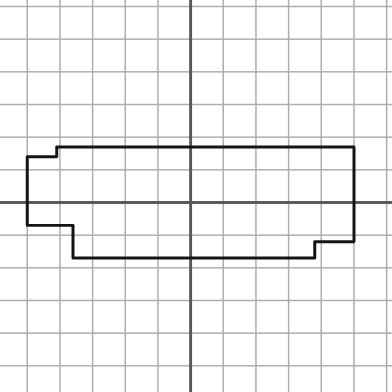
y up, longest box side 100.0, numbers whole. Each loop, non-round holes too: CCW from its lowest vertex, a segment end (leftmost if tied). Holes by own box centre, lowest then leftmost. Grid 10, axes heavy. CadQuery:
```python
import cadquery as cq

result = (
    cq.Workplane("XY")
    .moveTo(-36.0, -17.0)
    .lineTo(38.0, -17.0)
    .lineTo(38.0, -12.0)
    .lineTo(50.0, -12.0)
    .lineTo(50.0, 17.0)
    .lineTo(-41.0, 17.0)
    .lineTo(-41.0, 14.0)
    .lineTo(-50.0, 14.0)
    .lineTo(-50.0, -7.0)
    .lineTo(-36.0, -7.0)
    .close()
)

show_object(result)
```